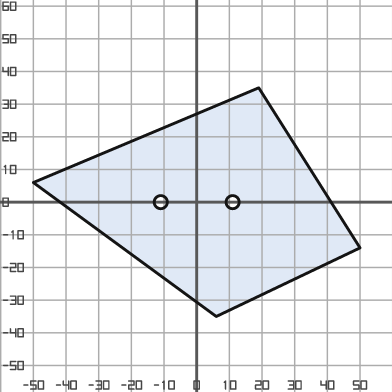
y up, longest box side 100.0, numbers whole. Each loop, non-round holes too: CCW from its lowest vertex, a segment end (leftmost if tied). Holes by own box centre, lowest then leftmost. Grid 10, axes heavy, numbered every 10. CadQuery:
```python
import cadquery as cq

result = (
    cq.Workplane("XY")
    .moveTo(6.0, -35.0)
    .lineTo(50.0, -14.0)
    .lineTo(19.0, 35.0)
    .lineTo(-50.0, 6.0)
    .close()
    .moveTo(-11.0, 0.0)
    .circle(2.0)
    .moveTo(11.0, 0.0)
    .circle(2.0)
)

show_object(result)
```